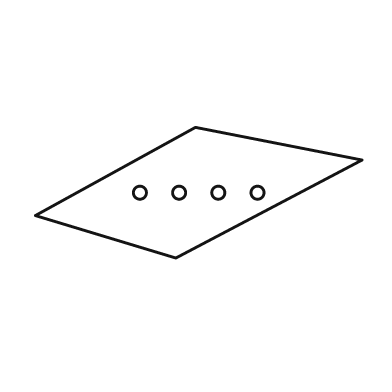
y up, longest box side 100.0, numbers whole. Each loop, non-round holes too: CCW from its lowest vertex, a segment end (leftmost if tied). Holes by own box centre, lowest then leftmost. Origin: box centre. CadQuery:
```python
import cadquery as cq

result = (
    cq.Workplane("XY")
    .moveTo(-7.0, -20.0)
    .lineTo(50.0, 10.0)
    .lineTo(-1.0, 20.0)
    .lineTo(-50.0, -7.0)
    .close()
    .moveTo(-18.0, 0.0)
    .circle(2.0)
    .moveTo(-6.0, 0.0)
    .circle(2.0)
    .moveTo(6.0, 0.0)
    .circle(2.0)
    .moveTo(18.0, 0.0)
    .circle(2.0)
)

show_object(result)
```